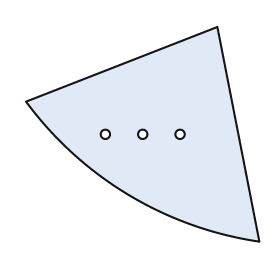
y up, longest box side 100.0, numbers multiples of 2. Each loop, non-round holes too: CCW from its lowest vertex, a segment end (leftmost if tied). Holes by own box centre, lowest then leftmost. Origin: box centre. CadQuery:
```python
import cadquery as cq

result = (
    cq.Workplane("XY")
    .moveTo(50.0, -46.0)
    .lineTo(32.0, 46.0)
    .lineTo(-50.0, 14.0)
    .threePointArc((-6.0, -26.0), (50.0, -46.0))
    .close()
    .moveTo(-16.0, 0.0)
    .circle(2.0)
    .moveTo(0.0, 0.0)
    .circle(2.0)
    .moveTo(16.0, 0.0)
    .circle(2.0)
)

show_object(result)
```